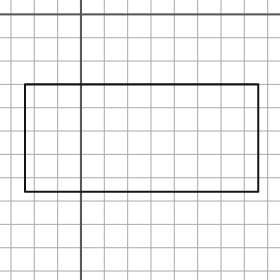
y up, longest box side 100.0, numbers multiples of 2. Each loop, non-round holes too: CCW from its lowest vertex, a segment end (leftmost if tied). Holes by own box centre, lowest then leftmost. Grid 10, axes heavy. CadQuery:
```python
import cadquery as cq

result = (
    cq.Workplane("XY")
    .moveTo(-24.0, -76.0)
    .lineTo(76.0, -76.0)
    .lineTo(76.0, -30.0)
    .lineTo(-24.0, -30.0)
    .close()
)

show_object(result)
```